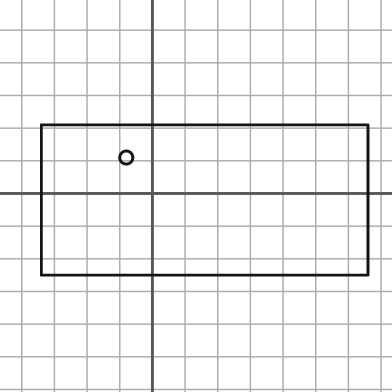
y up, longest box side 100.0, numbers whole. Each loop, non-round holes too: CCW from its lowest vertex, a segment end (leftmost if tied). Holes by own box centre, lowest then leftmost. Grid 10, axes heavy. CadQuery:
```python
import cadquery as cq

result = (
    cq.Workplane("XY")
    .moveTo(-34.0, -25.0)
    .lineTo(66.0, -25.0)
    .lineTo(66.0, 21.0)
    .lineTo(-34.0, 21.0)
    .close()
    .moveTo(-8.0, 11.0)
    .circle(2.0)
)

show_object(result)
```